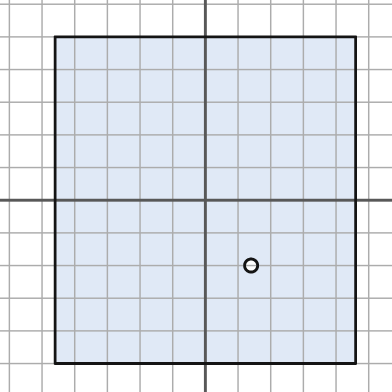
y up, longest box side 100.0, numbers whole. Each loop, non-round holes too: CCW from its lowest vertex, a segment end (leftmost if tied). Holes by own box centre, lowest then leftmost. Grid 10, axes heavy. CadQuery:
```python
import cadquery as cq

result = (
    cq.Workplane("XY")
    .moveTo(-46.0, -50.0)
    .lineTo(46.0, -50.0)
    .lineTo(46.0, 50.0)
    .lineTo(-46.0, 50.0)
    .close()
    .moveTo(14.0, -20.0)
    .circle(2.0)
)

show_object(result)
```